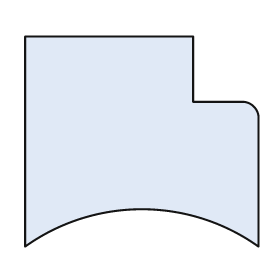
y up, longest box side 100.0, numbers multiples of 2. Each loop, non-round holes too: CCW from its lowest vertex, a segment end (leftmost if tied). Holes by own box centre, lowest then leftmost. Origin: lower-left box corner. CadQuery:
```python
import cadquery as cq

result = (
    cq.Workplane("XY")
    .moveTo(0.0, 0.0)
    .threePointArc((50.0, 16.0), (100.0, 0.0))
    .lineTo(100.0, 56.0)
    .threePointArc((98.0, 60.0), (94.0, 62.0))
    .lineTo(72.0, 62.0)
    .lineTo(72.0, 90.0)
    .lineTo(0.0, 90.0)
    .close()
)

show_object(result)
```